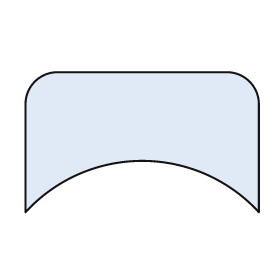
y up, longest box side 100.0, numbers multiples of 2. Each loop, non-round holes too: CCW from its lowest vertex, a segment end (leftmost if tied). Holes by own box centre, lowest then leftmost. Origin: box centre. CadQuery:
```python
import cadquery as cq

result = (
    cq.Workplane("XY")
    .moveTo(-50.0, -30.0)
    .threePointArc((0.0, -8.0), (50.0, -30.0))
    .lineTo(50.0, 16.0)
    .threePointArc((46.0, 26.0), (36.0, 30.0))
    .lineTo(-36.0, 30.0)
    .threePointArc((-46.0, 26.0), (-50.0, 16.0))
    .close()
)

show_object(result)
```